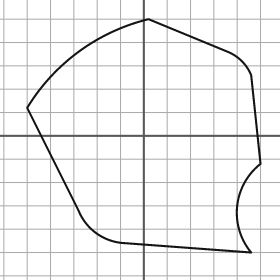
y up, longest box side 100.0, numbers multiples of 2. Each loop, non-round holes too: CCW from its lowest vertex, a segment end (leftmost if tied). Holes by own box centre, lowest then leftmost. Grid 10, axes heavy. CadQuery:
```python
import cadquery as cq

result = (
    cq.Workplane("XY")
    .moveTo(46.0, -50.0)
    .threePointArc((40.0, -30.0), (50.0, -12.0))
    .lineTo(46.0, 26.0)
    .threePointArc((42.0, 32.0), (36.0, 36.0))
    .lineTo(2.0, 50.0)
    .threePointArc((-28.0, 36.0), (-50.0, 12.0))
    .lineTo(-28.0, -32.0)
    .threePointArc((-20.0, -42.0), (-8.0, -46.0))
    .close()
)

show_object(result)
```